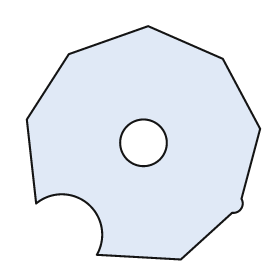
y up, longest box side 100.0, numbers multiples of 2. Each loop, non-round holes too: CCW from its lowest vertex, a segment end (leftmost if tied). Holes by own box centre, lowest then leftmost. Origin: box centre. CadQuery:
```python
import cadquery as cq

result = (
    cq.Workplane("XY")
    .moveTo(16.0, -50.0)
    .lineTo(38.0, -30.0)
    .threePointArc((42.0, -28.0), (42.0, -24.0))
    .lineTo(50.0, 6.0)
    .lineTo(34.0, 36.0)
    .lineTo(2.0, 50.0)
    .lineTo(-32.0, 38.0)
    .lineTo(-50.0, 10.0)
    .lineTo(-46.0, -26.0)
    .threePointArc((-24.0, -26.0), (-20.0, -48.0))
    .close()
    .moveTo(0.0, 0.0)
    .circle(10.0)
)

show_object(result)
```